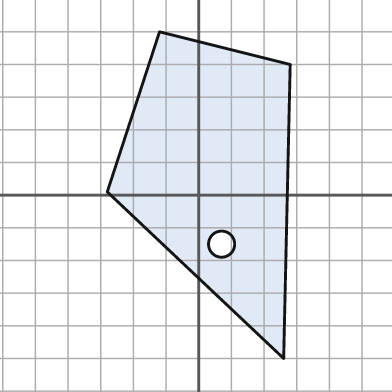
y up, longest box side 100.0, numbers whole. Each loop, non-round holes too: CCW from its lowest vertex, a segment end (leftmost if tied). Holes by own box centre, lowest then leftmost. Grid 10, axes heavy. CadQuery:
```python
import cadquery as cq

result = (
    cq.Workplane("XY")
    .moveTo(26.0, -50.0)
    .lineTo(28.0, 40.0)
    .lineTo(-12.0, 50.0)
    .lineTo(-28.0, 1.0)
    .close()
    .moveTo(7.0, -15.0)
    .circle(4.0)
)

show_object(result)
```